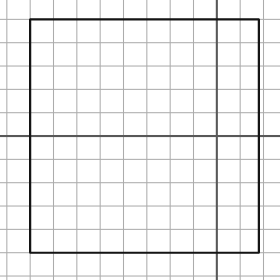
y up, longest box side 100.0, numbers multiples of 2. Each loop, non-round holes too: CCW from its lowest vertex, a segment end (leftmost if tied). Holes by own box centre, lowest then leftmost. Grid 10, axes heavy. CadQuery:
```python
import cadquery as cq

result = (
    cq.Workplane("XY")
    .moveTo(-80.0, -50.0)
    .lineTo(18.0, -50.0)
    .lineTo(18.0, 50.0)
    .lineTo(-80.0, 50.0)
    .close()
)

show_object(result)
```